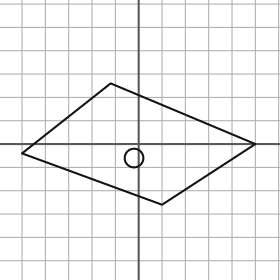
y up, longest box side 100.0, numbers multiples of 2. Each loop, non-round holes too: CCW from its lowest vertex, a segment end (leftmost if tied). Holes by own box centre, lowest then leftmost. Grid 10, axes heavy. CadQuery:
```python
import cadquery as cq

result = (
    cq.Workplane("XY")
    .moveTo(10.0, -26.0)
    .lineTo(50.0, 0.0)
    .lineTo(-12.0, 26.0)
    .lineTo(-50.0, -4.0)
    .close()
    .moveTo(-2.0, -6.0)
    .circle(4.0)
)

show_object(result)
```